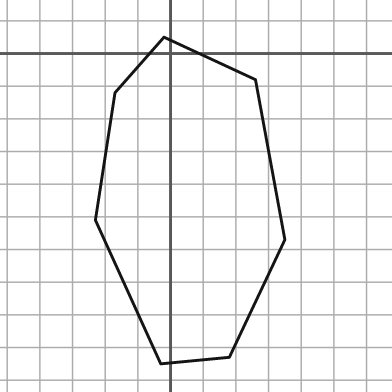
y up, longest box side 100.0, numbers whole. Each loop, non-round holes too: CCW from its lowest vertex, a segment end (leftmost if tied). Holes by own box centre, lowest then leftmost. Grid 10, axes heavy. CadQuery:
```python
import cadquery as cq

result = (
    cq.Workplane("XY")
    .moveTo(-3.0, -95.0)
    .lineTo(18.0, -93.0)
    .lineTo(35.0, -57.0)
    .lineTo(26.0, -8.0)
    .lineTo(-2.0, 5.0)
    .lineTo(-17.0, -12.0)
    .lineTo(-23.0, -51.0)
    .close()
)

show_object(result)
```